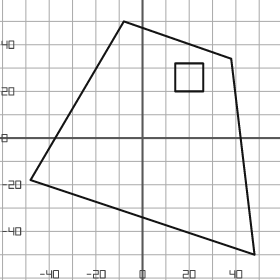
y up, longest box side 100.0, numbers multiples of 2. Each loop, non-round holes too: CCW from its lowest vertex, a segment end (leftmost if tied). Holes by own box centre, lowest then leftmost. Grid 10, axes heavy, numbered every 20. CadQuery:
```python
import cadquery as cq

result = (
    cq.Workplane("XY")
    .moveTo(48.0, -50.0)
    .lineTo(38.0, 34.0)
    .lineTo(-8.0, 50.0)
    .lineTo(-48.0, -18.0)
    .close()
    .moveTo(14.0, 20.0)
    .lineTo(26.0, 20.0)
    .lineTo(26.0, 32.0)
    .lineTo(14.0, 32.0)
    .close()
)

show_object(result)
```